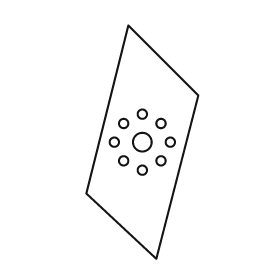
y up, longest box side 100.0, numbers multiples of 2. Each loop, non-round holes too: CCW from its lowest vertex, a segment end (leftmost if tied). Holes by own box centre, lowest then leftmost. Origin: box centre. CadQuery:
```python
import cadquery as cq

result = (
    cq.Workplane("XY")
    .moveTo(6.0, -50.0)
    .lineTo(24.0, 20.0)
    .lineTo(-6.0, 50.0)
    .lineTo(-24.0, -22.0)
    .close()
    .moveTo(0.0, -12.0)
    .circle(2.0)
    .moveTo(-8.0, -8.0)
    .circle(2.0)
    .moveTo(8.0, -8.0)
    .circle(2.0)
    .moveTo(-12.0, 0.0)
    .circle(2.0)
    .moveTo(0.0, 0.0)
    .circle(4.0)
    .moveTo(12.0, 0.0)
    .circle(2.0)
    .moveTo(-8.0, 8.0)
    .circle(2.0)
    .moveTo(8.0, 8.0)
    .circle(2.0)
    .moveTo(0.0, 12.0)
    .circle(2.0)
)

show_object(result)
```